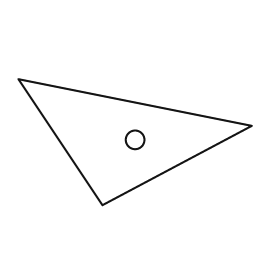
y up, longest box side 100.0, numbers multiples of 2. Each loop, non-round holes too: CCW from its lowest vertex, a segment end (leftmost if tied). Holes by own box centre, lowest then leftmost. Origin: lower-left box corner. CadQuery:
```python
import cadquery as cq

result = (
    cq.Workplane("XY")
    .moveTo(36.0, 0.0)
    .lineTo(100.0, 34.0)
    .lineTo(0.0, 54.0)
    .close()
    .moveTo(50.0, 28.0)
    .circle(4.0)
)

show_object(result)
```